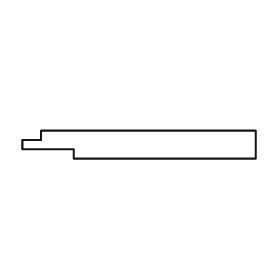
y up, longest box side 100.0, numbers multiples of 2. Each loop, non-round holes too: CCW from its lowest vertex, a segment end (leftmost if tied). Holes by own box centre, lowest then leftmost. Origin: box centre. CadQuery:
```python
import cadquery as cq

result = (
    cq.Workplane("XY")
    .moveTo(-28.0, -6.0)
    .lineTo(50.0, -6.0)
    .lineTo(50.0, 6.0)
    .lineTo(-42.0, 6.0)
    .lineTo(-42.0, 2.0)
    .lineTo(-50.0, 2.0)
    .lineTo(-50.0, -2.0)
    .lineTo(-28.0, -2.0)
    .close()
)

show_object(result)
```